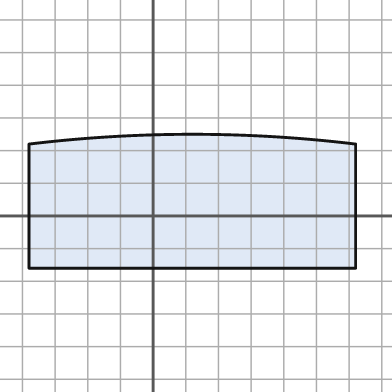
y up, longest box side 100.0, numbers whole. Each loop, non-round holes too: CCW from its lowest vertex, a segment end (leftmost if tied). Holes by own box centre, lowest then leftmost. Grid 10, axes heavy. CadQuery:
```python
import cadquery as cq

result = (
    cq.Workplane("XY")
    .moveTo(-38.0, -16.0)
    .lineTo(62.0, -16.0)
    .lineTo(62.0, 22.0)
    .threePointArc((12.0, 25.0), (-38.0, 22.0))
    .close()
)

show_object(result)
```